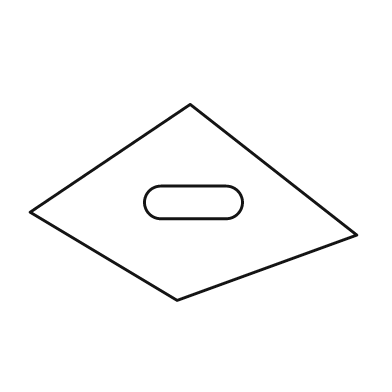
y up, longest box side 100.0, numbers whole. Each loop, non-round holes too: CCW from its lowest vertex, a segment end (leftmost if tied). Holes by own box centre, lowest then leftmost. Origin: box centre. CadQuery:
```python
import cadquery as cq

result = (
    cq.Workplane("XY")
    .moveTo(-5.0, -30.0)
    .lineTo(50.0, -10.0)
    .lineTo(-1.0, 30.0)
    .lineTo(-50.0, -3.0)
    .close()
    .moveTo(-10.0, -5.0)
    .lineTo(10.0, -5.0)
    .threePointArc((15.0, 0.0), (10.0, 5.0))
    .lineTo(-10.0, 5.0)
    .threePointArc((-15.0, 0.0), (-10.0, -5.0))
    .close()
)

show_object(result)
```